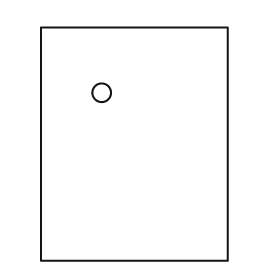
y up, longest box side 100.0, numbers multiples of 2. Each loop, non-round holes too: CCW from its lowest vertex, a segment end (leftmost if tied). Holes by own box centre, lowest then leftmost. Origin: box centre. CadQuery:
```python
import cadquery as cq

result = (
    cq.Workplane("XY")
    .moveTo(-40.0, -50.0)
    .lineTo(40.0, -50.0)
    .lineTo(40.0, 50.0)
    .lineTo(-40.0, 50.0)
    .close()
    .moveTo(-14.0, 22.0)
    .circle(4.0)
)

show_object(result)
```